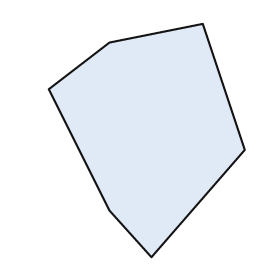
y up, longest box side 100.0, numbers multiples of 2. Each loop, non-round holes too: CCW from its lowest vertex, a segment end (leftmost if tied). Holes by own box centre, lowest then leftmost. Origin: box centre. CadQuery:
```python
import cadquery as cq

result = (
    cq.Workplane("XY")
    .moveTo(2.0, -50.0)
    .lineTo(42.0, -4.0)
    .lineTo(24.0, 50.0)
    .lineTo(-16.0, 42.0)
    .lineTo(-42.0, 22.0)
    .lineTo(-16.0, -30.0)
    .close()
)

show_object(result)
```